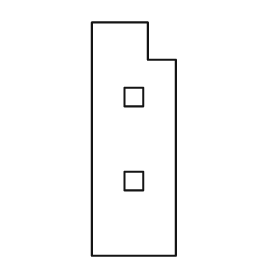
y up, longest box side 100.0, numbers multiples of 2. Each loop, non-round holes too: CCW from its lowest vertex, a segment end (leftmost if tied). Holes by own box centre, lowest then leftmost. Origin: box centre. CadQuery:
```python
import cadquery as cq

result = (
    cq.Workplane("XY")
    .moveTo(-18.0, -50.0)
    .lineTo(18.0, -50.0)
    .lineTo(18.0, 34.0)
    .lineTo(6.0, 34.0)
    .lineTo(6.0, 50.0)
    .lineTo(-18.0, 50.0)
    .close()
    .moveTo(-4.0, -22.0)
    .lineTo(4.0, -22.0)
    .lineTo(4.0, -14.0)
    .lineTo(-4.0, -14.0)
    .close()
    .moveTo(-4.0, 14.0)
    .lineTo(4.0, 14.0)
    .lineTo(4.0, 22.0)
    .lineTo(-4.0, 22.0)
    .close()
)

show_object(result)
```